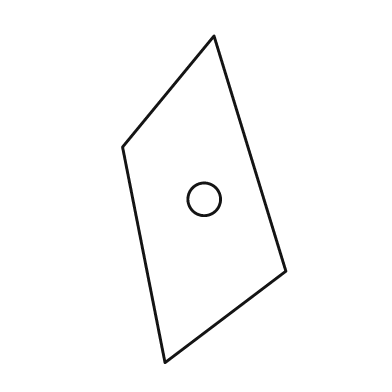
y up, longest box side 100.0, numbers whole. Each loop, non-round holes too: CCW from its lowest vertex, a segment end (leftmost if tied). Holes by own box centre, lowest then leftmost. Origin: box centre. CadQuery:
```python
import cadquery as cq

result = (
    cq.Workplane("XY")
    .moveTo(-12.0, -50.0)
    .lineTo(25.0, -22.0)
    .lineTo(3.0, 50.0)
    .lineTo(-25.0, 16.0)
    .close()
    .moveTo(0.0, 0.0)
    .circle(5.0)
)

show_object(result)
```